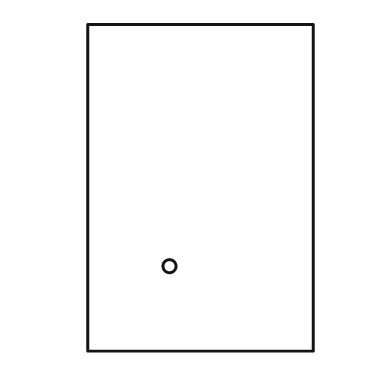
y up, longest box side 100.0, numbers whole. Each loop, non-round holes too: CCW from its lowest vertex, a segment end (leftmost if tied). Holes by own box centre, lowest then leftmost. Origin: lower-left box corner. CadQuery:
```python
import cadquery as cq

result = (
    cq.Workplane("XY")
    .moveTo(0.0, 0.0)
    .lineTo(69.0, 0.0)
    .lineTo(69.0, 100.0)
    .lineTo(0.0, 100.0)
    .close()
    .moveTo(25.0, 26.0)
    .circle(2.0)
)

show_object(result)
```